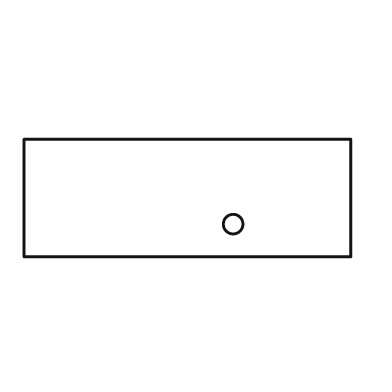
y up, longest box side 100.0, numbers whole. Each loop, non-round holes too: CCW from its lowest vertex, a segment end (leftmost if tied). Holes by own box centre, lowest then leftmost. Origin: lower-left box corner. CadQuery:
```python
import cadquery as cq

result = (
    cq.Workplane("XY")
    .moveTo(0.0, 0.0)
    .lineTo(100.0, 0.0)
    .lineTo(100.0, 36.0)
    .lineTo(0.0, 36.0)
    .close()
    .moveTo(64.0, 10.0)
    .circle(3.0)
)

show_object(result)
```